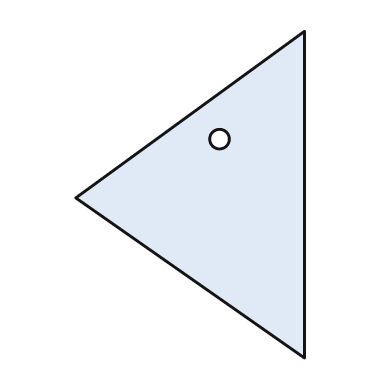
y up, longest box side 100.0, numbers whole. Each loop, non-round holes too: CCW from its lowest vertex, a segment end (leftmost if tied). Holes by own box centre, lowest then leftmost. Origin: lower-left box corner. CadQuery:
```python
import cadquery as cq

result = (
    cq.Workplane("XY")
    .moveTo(70.0, 0.0)
    .lineTo(70.0, 100.0)
    .lineTo(0.0, 49.0)
    .close()
    .moveTo(44.0, 67.0)
    .circle(3.0)
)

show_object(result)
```